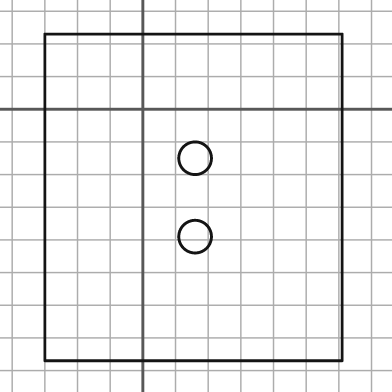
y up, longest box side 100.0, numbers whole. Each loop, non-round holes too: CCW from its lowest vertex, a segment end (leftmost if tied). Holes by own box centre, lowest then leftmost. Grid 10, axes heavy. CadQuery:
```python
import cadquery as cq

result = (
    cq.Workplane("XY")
    .moveTo(-30.0, -77.0)
    .lineTo(61.0, -77.0)
    .lineTo(61.0, 23.0)
    .lineTo(-30.0, 23.0)
    .close()
    .moveTo(16.0, -39.0)
    .circle(5.0)
    .moveTo(16.0, -15.0)
    .circle(5.0)
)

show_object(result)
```